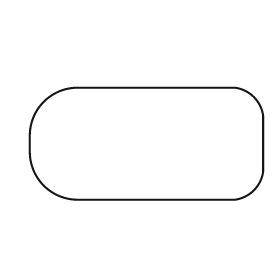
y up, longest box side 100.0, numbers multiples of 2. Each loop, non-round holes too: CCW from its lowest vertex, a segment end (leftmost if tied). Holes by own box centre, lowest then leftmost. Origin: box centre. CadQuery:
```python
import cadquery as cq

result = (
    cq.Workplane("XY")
    .moveTo(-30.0, -24.0)
    .lineTo(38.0, -24.0)
    .threePointArc((46.0, -20.0), (50.0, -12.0))
    .lineTo(50.0, 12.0)
    .threePointArc((46.0, 20.0), (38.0, 24.0))
    .lineTo(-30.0, 24.0)
    .threePointArc((-44.0, 18.0), (-50.0, 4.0))
    .lineTo(-50.0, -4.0)
    .threePointArc((-44.0, -18.0), (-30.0, -24.0))
    .close()
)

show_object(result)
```